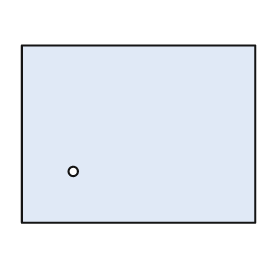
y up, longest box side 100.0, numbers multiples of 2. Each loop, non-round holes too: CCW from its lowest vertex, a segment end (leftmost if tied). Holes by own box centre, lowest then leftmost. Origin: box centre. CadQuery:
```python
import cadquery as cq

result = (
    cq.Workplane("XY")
    .moveTo(-50.0, -38.0)
    .lineTo(50.0, -38.0)
    .lineTo(50.0, 38.0)
    .lineTo(-50.0, 38.0)
    .close()
    .moveTo(-28.0, -16.0)
    .circle(2.0)
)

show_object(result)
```